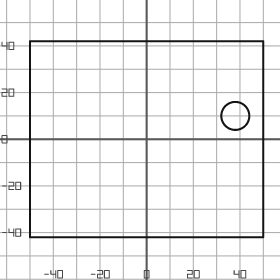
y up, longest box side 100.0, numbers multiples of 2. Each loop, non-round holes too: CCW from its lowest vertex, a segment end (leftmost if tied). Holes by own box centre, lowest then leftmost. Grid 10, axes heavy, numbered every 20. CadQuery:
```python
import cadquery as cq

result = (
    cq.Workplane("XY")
    .moveTo(-50.0, -42.0)
    .lineTo(50.0, -42.0)
    .lineTo(50.0, 42.0)
    .lineTo(-50.0, 42.0)
    .close()
    .moveTo(38.0, 10.0)
    .circle(6.0)
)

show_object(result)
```